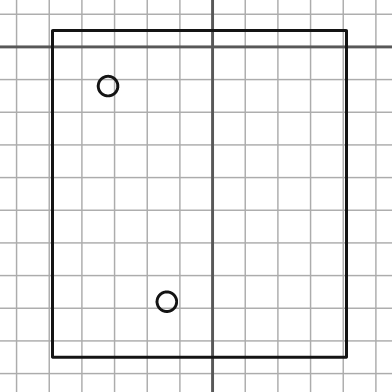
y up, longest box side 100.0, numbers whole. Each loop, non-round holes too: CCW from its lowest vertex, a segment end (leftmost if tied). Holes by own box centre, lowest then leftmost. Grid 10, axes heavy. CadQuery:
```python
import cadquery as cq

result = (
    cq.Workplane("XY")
    .moveTo(-49.0, -95.0)
    .lineTo(41.0, -95.0)
    .lineTo(41.0, 5.0)
    .lineTo(-49.0, 5.0)
    .close()
    .moveTo(-14.0, -78.0)
    .circle(3.0)
    .moveTo(-32.0, -12.0)
    .circle(3.0)
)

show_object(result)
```